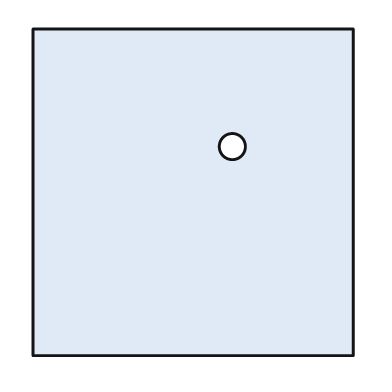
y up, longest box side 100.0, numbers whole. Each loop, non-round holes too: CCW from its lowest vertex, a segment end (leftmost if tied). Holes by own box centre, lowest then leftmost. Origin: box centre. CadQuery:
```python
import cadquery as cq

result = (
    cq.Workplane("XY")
    .moveTo(-49.0, -50.0)
    .lineTo(49.0, -50.0)
    .lineTo(49.0, 50.0)
    .lineTo(-49.0, 50.0)
    .close()
    .moveTo(12.0, 14.0)
    .circle(4.0)
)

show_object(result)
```